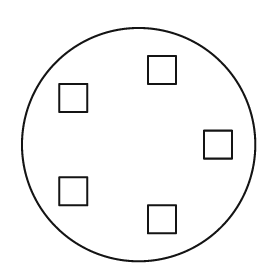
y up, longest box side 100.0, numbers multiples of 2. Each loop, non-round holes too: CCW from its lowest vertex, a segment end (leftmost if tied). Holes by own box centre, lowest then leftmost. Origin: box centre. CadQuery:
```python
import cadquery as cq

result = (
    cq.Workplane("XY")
    .moveTo(0.0, 0.0)
    .circle(50.0)
    .moveTo(4.0, -38.0)
    .lineTo(16.0, -38.0)
    .lineTo(16.0, -26.0)
    .lineTo(4.0, -26.0)
    .close()
    .moveTo(-34.0, -26.0)
    .lineTo(-22.0, -26.0)
    .lineTo(-22.0, -14.0)
    .lineTo(-34.0, -14.0)
    .close()
    .moveTo(28.0, -6.0)
    .lineTo(40.0, -6.0)
    .lineTo(40.0, 6.0)
    .lineTo(28.0, 6.0)
    .close()
    .moveTo(-34.0, 14.0)
    .lineTo(-22.0, 14.0)
    .lineTo(-22.0, 26.0)
    .lineTo(-34.0, 26.0)
    .close()
    .moveTo(4.0, 26.0)
    .lineTo(16.0, 26.0)
    .lineTo(16.0, 38.0)
    .lineTo(4.0, 38.0)
    .close()
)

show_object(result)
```